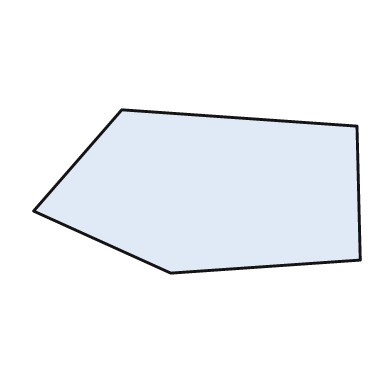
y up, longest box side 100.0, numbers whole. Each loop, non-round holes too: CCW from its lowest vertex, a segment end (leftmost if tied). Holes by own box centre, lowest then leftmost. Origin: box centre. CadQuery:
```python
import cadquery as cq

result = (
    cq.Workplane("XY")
    .moveTo(-8.0, -25.0)
    .lineTo(50.0, -21.0)
    .lineTo(49.0, 20.0)
    .lineTo(-23.0, 25.0)
    .lineTo(-50.0, -6.0)
    .close()
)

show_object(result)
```